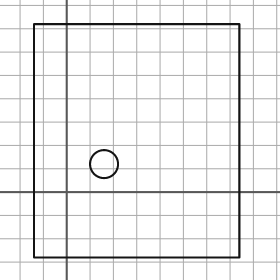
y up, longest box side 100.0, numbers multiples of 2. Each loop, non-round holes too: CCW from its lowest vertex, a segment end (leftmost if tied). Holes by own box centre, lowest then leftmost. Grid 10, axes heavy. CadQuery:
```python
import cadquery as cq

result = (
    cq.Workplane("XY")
    .moveTo(-14.0, -28.0)
    .lineTo(74.0, -28.0)
    .lineTo(74.0, 72.0)
    .lineTo(-14.0, 72.0)
    .close()
    .moveTo(16.0, 12.0)
    .circle(6.0)
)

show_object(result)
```